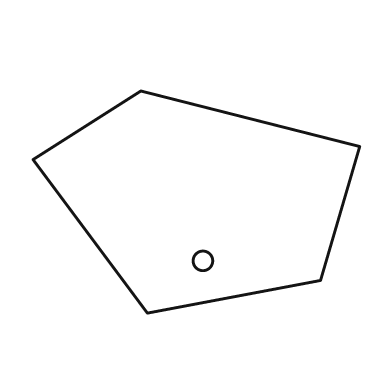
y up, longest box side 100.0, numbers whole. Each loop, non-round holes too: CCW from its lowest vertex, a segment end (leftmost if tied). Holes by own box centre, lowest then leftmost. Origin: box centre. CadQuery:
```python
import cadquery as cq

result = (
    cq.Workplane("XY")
    .moveTo(-15.0, -34.0)
    .lineTo(38.0, -24.0)
    .lineTo(50.0, 17.0)
    .lineTo(-17.0, 34.0)
    .lineTo(-50.0, 13.0)
    .close()
    .moveTo(2.0, -18.0)
    .circle(3.0)
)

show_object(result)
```